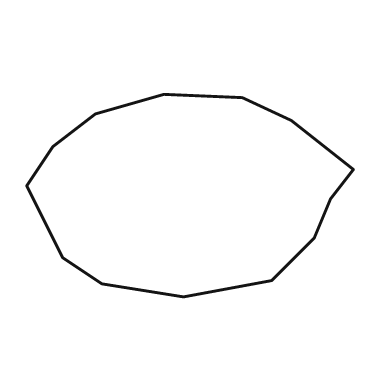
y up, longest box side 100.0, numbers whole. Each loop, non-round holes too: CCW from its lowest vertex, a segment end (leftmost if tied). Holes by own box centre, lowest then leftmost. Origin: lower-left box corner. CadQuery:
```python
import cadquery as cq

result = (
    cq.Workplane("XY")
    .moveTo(48.0, 0.0)
    .lineTo(75.0, 5.0)
    .lineTo(88.0, 18.0)
    .lineTo(93.0, 30.0)
    .lineTo(100.0, 39.0)
    .lineTo(81.0, 54.0)
    .lineTo(66.0, 61.0)
    .lineTo(42.0, 62.0)
    .lineTo(21.0, 56.0)
    .lineTo(8.0, 46.0)
    .lineTo(0.0, 34.0)
    .lineTo(11.0, 12.0)
    .lineTo(23.0, 4.0)
    .close()
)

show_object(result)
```